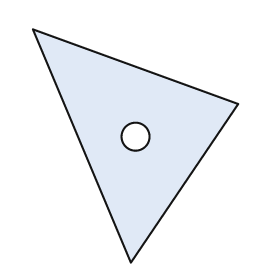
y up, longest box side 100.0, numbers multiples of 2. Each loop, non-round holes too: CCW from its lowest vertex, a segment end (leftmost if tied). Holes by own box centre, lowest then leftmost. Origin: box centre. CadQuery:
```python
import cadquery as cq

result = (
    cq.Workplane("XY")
    .moveTo(-2.0, -50.0)
    .lineTo(44.0, 18.0)
    .lineTo(-44.0, 50.0)
    .close()
    .moveTo(0.0, 4.0)
    .circle(6.0)
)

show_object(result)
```